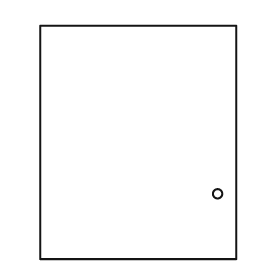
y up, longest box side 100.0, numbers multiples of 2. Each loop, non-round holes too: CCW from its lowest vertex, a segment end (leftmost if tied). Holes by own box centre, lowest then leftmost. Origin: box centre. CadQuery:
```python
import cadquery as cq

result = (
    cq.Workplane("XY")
    .moveTo(-42.0, -50.0)
    .lineTo(42.0, -50.0)
    .lineTo(42.0, 50.0)
    .lineTo(-42.0, 50.0)
    .close()
    .moveTo(34.0, -22.0)
    .circle(2.0)
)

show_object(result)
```